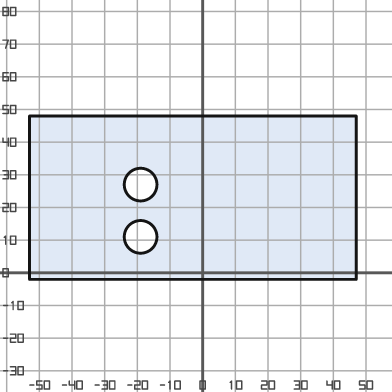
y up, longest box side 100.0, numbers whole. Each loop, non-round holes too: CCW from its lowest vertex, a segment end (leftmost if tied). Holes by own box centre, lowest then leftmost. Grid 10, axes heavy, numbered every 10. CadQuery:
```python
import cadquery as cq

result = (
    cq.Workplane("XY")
    .moveTo(-53.0, -2.0)
    .lineTo(47.0, -2.0)
    .lineTo(47.0, 48.0)
    .lineTo(-53.0, 48.0)
    .close()
    .moveTo(-19.0, 11.0)
    .circle(5.0)
    .moveTo(-19.0, 27.0)
    .circle(5.0)
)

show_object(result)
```